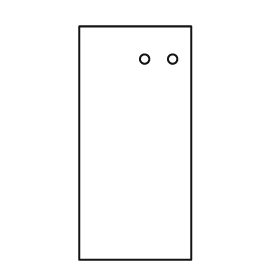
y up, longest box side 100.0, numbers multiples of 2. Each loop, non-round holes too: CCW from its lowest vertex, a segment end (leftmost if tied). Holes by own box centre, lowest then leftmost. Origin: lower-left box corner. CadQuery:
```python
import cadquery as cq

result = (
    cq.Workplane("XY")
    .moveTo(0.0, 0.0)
    .lineTo(48.0, 0.0)
    .lineTo(48.0, 100.0)
    .lineTo(0.0, 100.0)
    .close()
    .moveTo(28.0, 86.0)
    .circle(2.0)
    .moveTo(40.0, 86.0)
    .circle(2.0)
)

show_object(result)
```